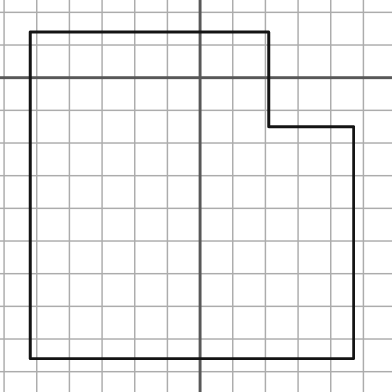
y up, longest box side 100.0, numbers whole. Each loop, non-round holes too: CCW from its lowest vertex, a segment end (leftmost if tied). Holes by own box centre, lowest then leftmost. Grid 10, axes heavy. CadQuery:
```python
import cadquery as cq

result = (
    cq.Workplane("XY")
    .moveTo(-52.0, -86.0)
    .lineTo(47.0, -86.0)
    .lineTo(47.0, -15.0)
    .lineTo(21.0, -15.0)
    .lineTo(21.0, 14.0)
    .lineTo(-52.0, 14.0)
    .close()
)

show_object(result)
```